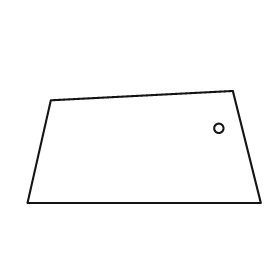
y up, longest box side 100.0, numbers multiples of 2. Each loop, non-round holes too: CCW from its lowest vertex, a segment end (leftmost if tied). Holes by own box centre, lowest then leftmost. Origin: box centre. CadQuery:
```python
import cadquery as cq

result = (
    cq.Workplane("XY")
    .moveTo(-50.0, -24.0)
    .lineTo(50.0, -24.0)
    .lineTo(38.0, 24.0)
    .lineTo(-40.0, 20.0)
    .close()
    .moveTo(32.0, 8.0)
    .circle(2.0)
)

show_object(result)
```